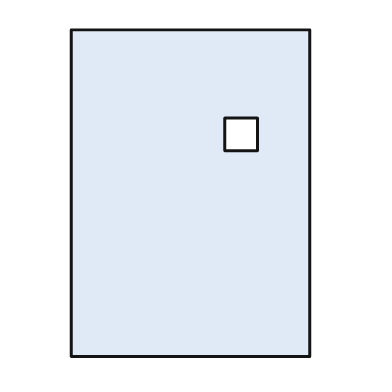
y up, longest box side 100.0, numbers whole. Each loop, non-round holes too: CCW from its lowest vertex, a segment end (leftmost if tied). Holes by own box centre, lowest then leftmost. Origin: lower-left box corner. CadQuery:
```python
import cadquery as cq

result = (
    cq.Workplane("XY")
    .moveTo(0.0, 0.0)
    .lineTo(73.0, 0.0)
    .lineTo(73.0, 100.0)
    .lineTo(0.0, 100.0)
    .close()
    .moveTo(47.0, 63.0)
    .lineTo(57.0, 63.0)
    .lineTo(57.0, 73.0)
    .lineTo(47.0, 73.0)
    .close()
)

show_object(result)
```